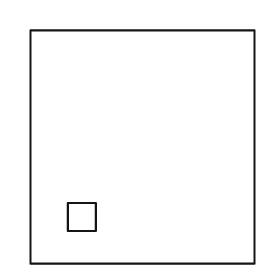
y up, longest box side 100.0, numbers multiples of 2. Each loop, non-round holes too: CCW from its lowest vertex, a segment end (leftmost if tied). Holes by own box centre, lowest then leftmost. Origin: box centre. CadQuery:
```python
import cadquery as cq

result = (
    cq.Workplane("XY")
    .moveTo(-48.0, -50.0)
    .lineTo(48.0, -50.0)
    .lineTo(48.0, 50.0)
    .lineTo(-48.0, 50.0)
    .close()
    .moveTo(-32.0, -36.0)
    .lineTo(-20.0, -36.0)
    .lineTo(-20.0, -24.0)
    .lineTo(-32.0, -24.0)
    .close()
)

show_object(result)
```